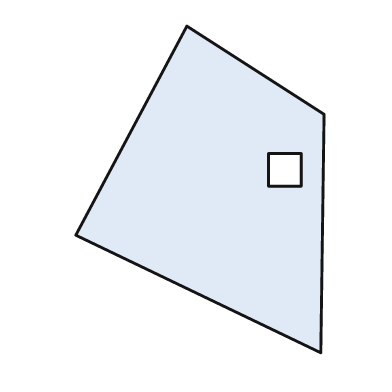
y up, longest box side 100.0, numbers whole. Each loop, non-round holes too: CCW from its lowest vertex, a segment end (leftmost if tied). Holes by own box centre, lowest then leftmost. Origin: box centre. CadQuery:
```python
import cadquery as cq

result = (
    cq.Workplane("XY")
    .moveTo(37.0, -50.0)
    .lineTo(38.0, 23.0)
    .lineTo(-4.0, 50.0)
    .lineTo(-38.0, -14.0)
    .close()
    .moveTo(21.0, 1.0)
    .lineTo(31.0, 1.0)
    .lineTo(31.0, 11.0)
    .lineTo(21.0, 11.0)
    .close()
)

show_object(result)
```